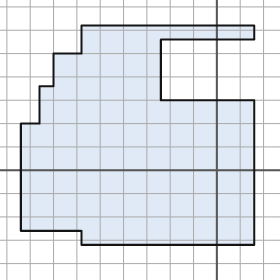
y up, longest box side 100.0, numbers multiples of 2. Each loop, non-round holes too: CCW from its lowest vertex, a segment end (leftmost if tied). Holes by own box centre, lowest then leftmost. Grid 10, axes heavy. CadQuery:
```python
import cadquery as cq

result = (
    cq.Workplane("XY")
    .moveTo(-58.0, -32.0)
    .lineTo(16.0, -32.0)
    .lineTo(16.0, 30.0)
    .lineTo(-24.0, 30.0)
    .lineTo(-24.0, 56.0)
    .lineTo(16.0, 56.0)
    .lineTo(16.0, 62.0)
    .lineTo(-58.0, 62.0)
    .lineTo(-58.0, 50.0)
    .lineTo(-70.0, 50.0)
    .lineTo(-70.0, 36.0)
    .lineTo(-76.0, 36.0)
    .lineTo(-76.0, 20.0)
    .lineTo(-84.0, 20.0)
    .lineTo(-84.0, -26.0)
    .lineTo(-58.0, -26.0)
    .close()
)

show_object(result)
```